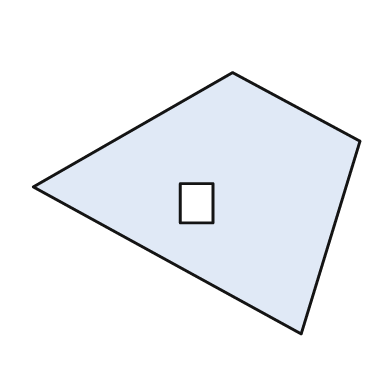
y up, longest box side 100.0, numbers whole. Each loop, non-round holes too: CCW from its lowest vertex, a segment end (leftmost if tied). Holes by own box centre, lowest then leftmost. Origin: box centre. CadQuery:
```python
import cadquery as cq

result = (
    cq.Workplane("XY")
    .moveTo(32.0, -40.0)
    .lineTo(50.0, 19.0)
    .lineTo(11.0, 40.0)
    .lineTo(-50.0, 5.0)
    .close()
    .moveTo(-5.0, -6.0)
    .lineTo(5.0, -6.0)
    .lineTo(5.0, 6.0)
    .lineTo(-5.0, 6.0)
    .close()
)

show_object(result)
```